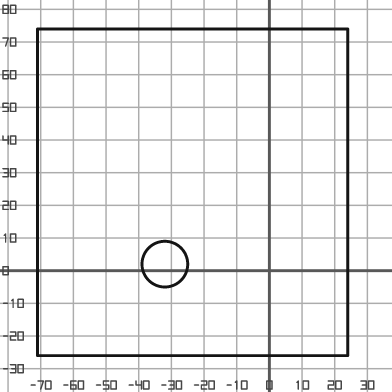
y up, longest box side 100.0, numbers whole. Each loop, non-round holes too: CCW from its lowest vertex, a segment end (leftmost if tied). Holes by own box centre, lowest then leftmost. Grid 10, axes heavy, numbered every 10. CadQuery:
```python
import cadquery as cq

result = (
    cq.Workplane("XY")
    .moveTo(-71.0, -26.0)
    .lineTo(24.0, -26.0)
    .lineTo(24.0, 74.0)
    .lineTo(-71.0, 74.0)
    .close()
    .moveTo(-32.0, 2.0)
    .circle(7.0)
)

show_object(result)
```